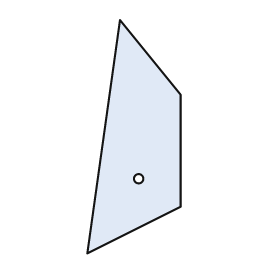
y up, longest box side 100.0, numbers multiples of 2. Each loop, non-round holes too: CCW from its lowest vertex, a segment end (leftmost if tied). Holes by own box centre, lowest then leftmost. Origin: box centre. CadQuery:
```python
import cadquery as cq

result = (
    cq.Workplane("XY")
    .moveTo(-20.0, -50.0)
    .lineTo(20.0, -30.0)
    .lineTo(20.0, 18.0)
    .lineTo(-6.0, 50.0)
    .close()
    .moveTo(2.0, -18.0)
    .circle(2.0)
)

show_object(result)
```